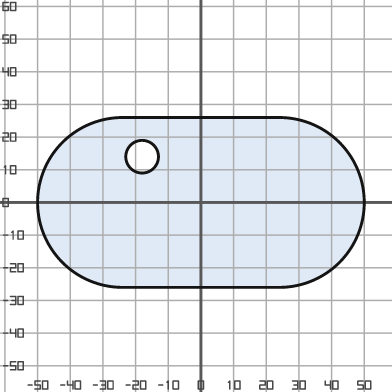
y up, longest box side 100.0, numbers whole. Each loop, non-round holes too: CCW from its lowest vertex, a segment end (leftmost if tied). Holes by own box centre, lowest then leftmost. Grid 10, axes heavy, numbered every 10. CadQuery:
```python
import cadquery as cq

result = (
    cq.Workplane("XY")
    .moveTo(-24.0, -26.0)
    .lineTo(24.0, -26.0)
    .threePointArc((50.0, 0.0), (24.0, 26.0))
    .lineTo(-24.0, 26.0)
    .threePointArc((-50.0, 0.0), (-24.0, -26.0))
    .close()
    .moveTo(-18.0, 14.0)
    .circle(5.0)
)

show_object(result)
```